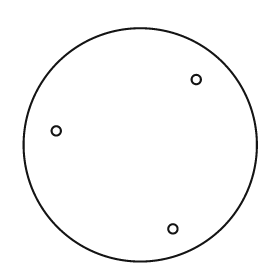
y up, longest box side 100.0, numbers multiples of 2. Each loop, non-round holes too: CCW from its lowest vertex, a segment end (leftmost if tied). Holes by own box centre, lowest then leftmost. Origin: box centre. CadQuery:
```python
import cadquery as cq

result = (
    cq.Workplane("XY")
    .moveTo(0.0, 0.0)
    .circle(50.0)
    .moveTo(14.0, -36.0)
    .circle(2.0)
    .moveTo(-36.0, 6.0)
    .circle(2.0)
    .moveTo(24.0, 28.0)
    .circle(2.0)
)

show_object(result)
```